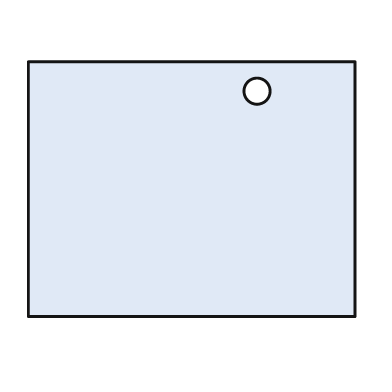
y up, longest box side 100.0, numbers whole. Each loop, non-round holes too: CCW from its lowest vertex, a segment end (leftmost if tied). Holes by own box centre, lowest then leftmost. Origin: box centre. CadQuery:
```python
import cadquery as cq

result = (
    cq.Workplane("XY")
    .moveTo(-50.0, -39.0)
    .lineTo(50.0, -39.0)
    .lineTo(50.0, 39.0)
    .lineTo(-50.0, 39.0)
    .close()
    .moveTo(20.0, 30.0)
    .circle(4.0)
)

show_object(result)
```